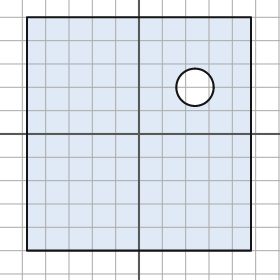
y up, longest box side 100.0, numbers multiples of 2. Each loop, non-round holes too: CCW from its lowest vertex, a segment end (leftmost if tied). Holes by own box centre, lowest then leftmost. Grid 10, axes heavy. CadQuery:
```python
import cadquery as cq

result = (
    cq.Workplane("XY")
    .moveTo(-48.0, -50.0)
    .lineTo(48.0, -50.0)
    .lineTo(48.0, 50.0)
    .lineTo(-48.0, 50.0)
    .close()
    .moveTo(24.0, 20.0)
    .circle(8.0)
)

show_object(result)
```